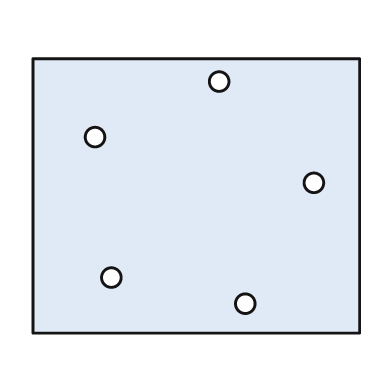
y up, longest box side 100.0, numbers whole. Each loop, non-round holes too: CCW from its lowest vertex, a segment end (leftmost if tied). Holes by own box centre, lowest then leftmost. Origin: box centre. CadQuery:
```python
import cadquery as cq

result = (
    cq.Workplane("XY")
    .moveTo(-50.0, -42.0)
    .lineTo(50.0, -42.0)
    .lineTo(50.0, 42.0)
    .lineTo(-50.0, 42.0)
    .close()
    .moveTo(15.0, -33.0)
    .circle(3.0)
    .moveTo(-26.0, -25.0)
    .circle(3.0)
    .moveTo(36.0, 4.0)
    .circle(3.0)
    .moveTo(-31.0, 18.0)
    .circle(3.0)
    .moveTo(7.0, 35.0)
    .circle(3.0)
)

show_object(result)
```